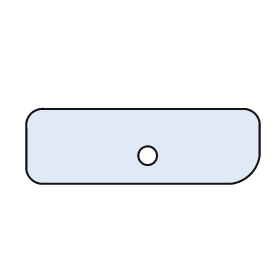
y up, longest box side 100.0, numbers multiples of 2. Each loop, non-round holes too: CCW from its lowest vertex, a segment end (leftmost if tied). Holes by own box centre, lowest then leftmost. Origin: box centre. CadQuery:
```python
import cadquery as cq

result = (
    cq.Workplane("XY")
    .moveTo(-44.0, -16.0)
    .lineTo(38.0, -16.0)
    .threePointArc((46.0, -12.0), (50.0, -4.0))
    .lineTo(50.0, 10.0)
    .threePointArc((48.0, 14.0), (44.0, 16.0))
    .lineTo(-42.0, 16.0)
    .threePointArc((-48.0, 14.0), (-50.0, 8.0))
    .lineTo(-50.0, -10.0)
    .threePointArc((-48.0, -14.0), (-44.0, -16.0))
    .close()
    .moveTo(2.0, -4.0)
    .circle(4.0)
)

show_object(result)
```